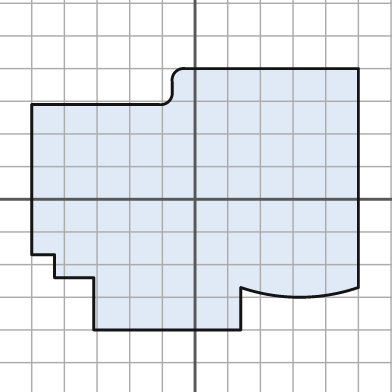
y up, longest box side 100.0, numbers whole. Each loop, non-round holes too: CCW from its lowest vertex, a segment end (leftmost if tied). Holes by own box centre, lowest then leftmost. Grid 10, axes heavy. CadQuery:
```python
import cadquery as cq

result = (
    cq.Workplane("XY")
    .moveTo(-31.0, -40.0)
    .lineTo(14.0, -40.0)
    .lineTo(14.0, -27.0)
    .threePointArc((32.0, -30.0), (50.0, -27.0))
    .lineTo(50.0, 40.0)
    .lineTo(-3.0, 40.0)
    .threePointArc((-6.0, 39.0), (-7.0, 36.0))
    .lineTo(-7.0, 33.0)
    .threePointArc((-8.0, 30.0), (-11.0, 29.0))
    .lineTo(-50.0, 29.0)
    .lineTo(-50.0, -17.0)
    .lineTo(-43.0, -17.0)
    .lineTo(-43.0, -24.0)
    .lineTo(-31.0, -24.0)
    .close()
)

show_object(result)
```